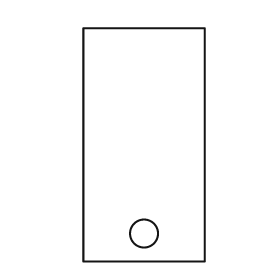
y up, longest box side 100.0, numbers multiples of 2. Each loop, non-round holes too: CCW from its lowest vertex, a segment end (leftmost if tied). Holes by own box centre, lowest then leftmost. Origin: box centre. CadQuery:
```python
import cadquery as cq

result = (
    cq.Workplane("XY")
    .moveTo(-26.0, -50.0)
    .lineTo(26.0, -50.0)
    .lineTo(26.0, 50.0)
    .lineTo(-26.0, 50.0)
    .close()
    .moveTo(0.0, -38.0)
    .circle(6.0)
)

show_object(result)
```